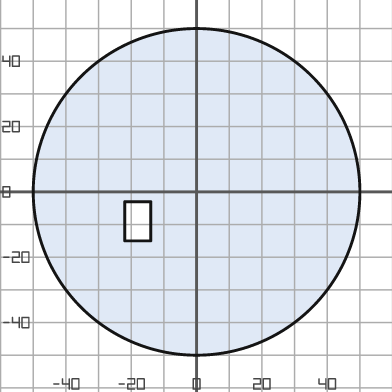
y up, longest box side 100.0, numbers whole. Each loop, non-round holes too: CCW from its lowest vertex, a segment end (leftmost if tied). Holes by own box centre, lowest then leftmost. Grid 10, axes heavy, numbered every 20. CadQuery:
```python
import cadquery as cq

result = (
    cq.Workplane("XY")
    .moveTo(0.0, 0.0)
    .circle(50.0)
    .moveTo(-22.0, -15.0)
    .lineTo(-14.0, -15.0)
    .lineTo(-14.0, -3.0)
    .lineTo(-22.0, -3.0)
    .close()
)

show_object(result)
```